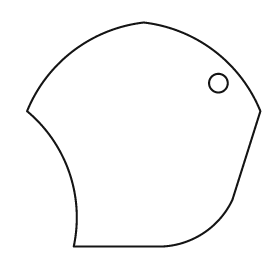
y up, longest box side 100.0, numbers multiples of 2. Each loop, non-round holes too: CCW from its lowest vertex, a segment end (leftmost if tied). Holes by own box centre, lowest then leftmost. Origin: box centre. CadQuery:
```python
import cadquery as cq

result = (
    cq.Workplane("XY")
    .moveTo(-30.0, -48.0)
    .lineTo(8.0, -48.0)
    .threePointArc((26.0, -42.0), (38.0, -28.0))
    .lineTo(50.0, 10.0)
    .threePointArc((30.0, 36.0), (0.0, 48.0))
    .threePointArc((-30.0, 36.0), (-50.0, 10.0))
    .threePointArc((-32.0, -16.0), (-30.0, -48.0))
    .close()
    .moveTo(32.0, 22.0)
    .circle(4.0)
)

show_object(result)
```